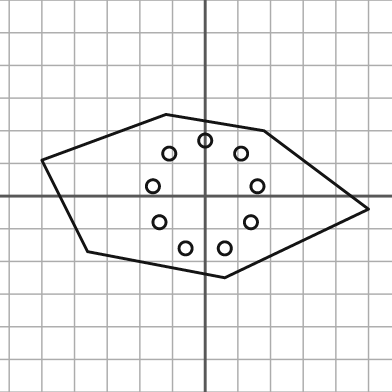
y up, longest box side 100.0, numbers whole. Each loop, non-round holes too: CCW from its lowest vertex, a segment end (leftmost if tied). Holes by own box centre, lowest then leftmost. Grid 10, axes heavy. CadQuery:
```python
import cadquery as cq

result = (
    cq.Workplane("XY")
    .moveTo(6.0, -25.0)
    .lineTo(50.0, -4.0)
    .lineTo(18.0, 20.0)
    .lineTo(-12.0, 25.0)
    .lineTo(-50.0, 11.0)
    .lineTo(-36.0, -17.0)
    .close()
    .moveTo(-6.0, -16.0)
    .circle(2.0)
    .moveTo(6.0, -16.0)
    .circle(2.0)
    .moveTo(-14.0, -8.0)
    .circle(2.0)
    .moveTo(14.0, -8.0)
    .circle(2.0)
    .moveTo(-16.0, 3.0)
    .circle(2.0)
    .moveTo(16.0, 3.0)
    .circle(2.0)
    .moveTo(-11.0, 13.0)
    .circle(2.0)
    .moveTo(11.0, 13.0)
    .circle(2.0)
    .moveTo(0.0, 17.0)
    .circle(2.0)
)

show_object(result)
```